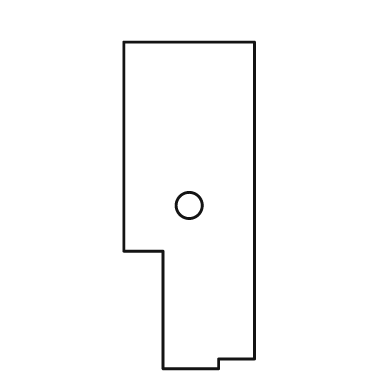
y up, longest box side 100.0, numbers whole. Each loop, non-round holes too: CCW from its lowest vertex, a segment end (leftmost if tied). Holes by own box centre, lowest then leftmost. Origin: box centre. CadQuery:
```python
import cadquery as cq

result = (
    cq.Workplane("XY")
    .moveTo(-8.0, -50.0)
    .lineTo(9.0, -50.0)
    .lineTo(9.0, -47.0)
    .lineTo(20.0, -47.0)
    .lineTo(20.0, 50.0)
    .lineTo(-20.0, 50.0)
    .lineTo(-20.0, -14.0)
    .lineTo(-8.0, -14.0)
    .close()
    .moveTo(0.0, 0.0)
    .circle(4.0)
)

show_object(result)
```